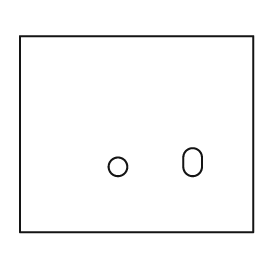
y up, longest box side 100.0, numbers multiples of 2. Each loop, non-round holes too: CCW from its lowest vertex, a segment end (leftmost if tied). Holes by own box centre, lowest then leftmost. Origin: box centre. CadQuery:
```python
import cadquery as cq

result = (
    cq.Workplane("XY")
    .moveTo(-50.0, -42.0)
    .lineTo(50.0, -42.0)
    .lineTo(50.0, 42.0)
    .lineTo(-50.0, 42.0)
    .close()
    .moveTo(-8.0, -14.0)
    .circle(4.0)
    .moveTo(20.0, -14.0)
    .threePointArc((24.0, -18.0), (28.0, -14.0))
    .lineTo(28.0, -10.0)
    .threePointArc((24.0, -6.0), (20.0, -10.0))
    .close()
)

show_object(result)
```